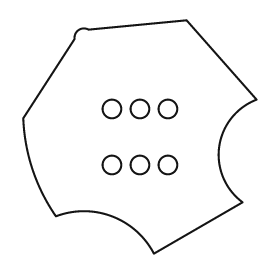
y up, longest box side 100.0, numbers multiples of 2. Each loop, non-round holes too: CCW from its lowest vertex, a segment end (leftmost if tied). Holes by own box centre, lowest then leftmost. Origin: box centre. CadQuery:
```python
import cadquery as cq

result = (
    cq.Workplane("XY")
    .moveTo(6.0, -50.0)
    .lineTo(44.0, -28.0)
    .threePointArc((34.0, -4.0), (50.0, 16.0))
    .lineTo(20.0, 50.0)
    .lineTo(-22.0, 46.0)
    .threePointArc((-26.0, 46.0), (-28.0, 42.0))
    .lineTo(-50.0, 8.0)
    .threePointArc((-46.0, -14.0), (-36.0, -34.0))
    .threePointArc((-12.0, -34.0), (6.0, -50.0))
    .close()
    .moveTo(-12.0, -12.0)
    .circle(4.0)
    .moveTo(0.0, -12.0)
    .circle(4.0)
    .moveTo(12.0, -12.0)
    .circle(4.0)
    .moveTo(-12.0, 12.0)
    .circle(4.0)
    .moveTo(0.0, 12.0)
    .circle(4.0)
    .moveTo(12.0, 12.0)
    .circle(4.0)
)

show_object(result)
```